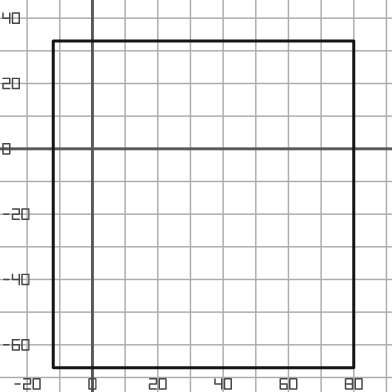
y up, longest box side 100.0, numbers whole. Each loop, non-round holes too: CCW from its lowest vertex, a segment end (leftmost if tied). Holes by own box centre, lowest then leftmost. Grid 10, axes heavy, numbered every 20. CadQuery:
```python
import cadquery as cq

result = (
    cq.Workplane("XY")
    .moveTo(-12.0, -67.0)
    .lineTo(80.0, -67.0)
    .lineTo(80.0, 33.0)
    .lineTo(-12.0, 33.0)
    .close()
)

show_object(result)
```